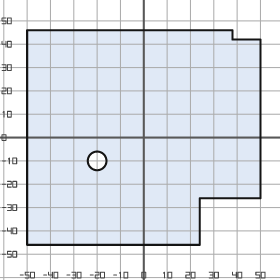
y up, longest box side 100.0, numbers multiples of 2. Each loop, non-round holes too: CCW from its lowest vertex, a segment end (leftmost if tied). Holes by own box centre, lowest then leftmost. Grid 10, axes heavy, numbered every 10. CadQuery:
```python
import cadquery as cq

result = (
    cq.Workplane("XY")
    .moveTo(-50.0, -46.0)
    .lineTo(24.0, -46.0)
    .lineTo(24.0, -26.0)
    .lineTo(50.0, -26.0)
    .lineTo(50.0, 42.0)
    .lineTo(38.0, 42.0)
    .lineTo(38.0, 46.0)
    .lineTo(-50.0, 46.0)
    .close()
    .moveTo(-20.0, -10.0)
    .circle(4.0)
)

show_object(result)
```